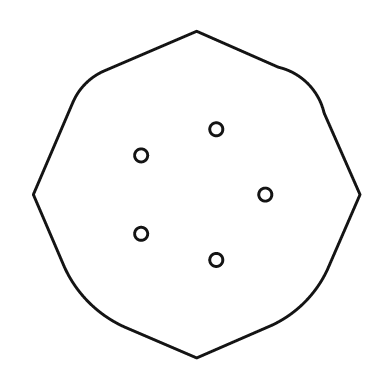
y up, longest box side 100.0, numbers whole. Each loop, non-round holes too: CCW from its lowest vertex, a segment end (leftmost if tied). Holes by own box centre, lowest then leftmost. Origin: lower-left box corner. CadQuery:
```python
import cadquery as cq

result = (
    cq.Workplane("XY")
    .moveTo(50.0, 0.0)
    .lineTo(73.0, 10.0)
    .threePointArc((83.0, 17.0), (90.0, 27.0))
    .lineTo(100.0, 50.0)
    .lineTo(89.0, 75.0)
    .threePointArc((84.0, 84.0), (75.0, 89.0))
    .lineTo(50.0, 100.0)
    .lineTo(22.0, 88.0)
    .threePointArc((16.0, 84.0), (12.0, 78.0))
    .lineTo(0.0, 50.0)
    .lineTo(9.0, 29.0)
    .threePointArc((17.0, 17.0), (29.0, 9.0))
    .close()
    .moveTo(56.0, 30.0)
    .circle(2.0)
    .moveTo(33.0, 38.0)
    .circle(2.0)
    .moveTo(71.0, 50.0)
    .circle(2.0)
    .moveTo(33.0, 62.0)
    .circle(2.0)
    .moveTo(56.0, 70.0)
    .circle(2.0)
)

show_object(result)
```